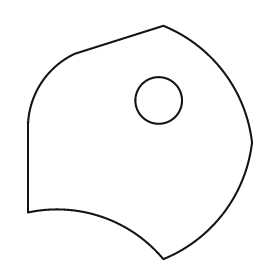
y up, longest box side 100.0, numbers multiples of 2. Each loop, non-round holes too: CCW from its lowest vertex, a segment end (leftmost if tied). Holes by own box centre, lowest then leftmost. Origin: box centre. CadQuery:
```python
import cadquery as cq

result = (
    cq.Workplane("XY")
    .moveTo(10.0, -50.0)
    .threePointArc((36.0, -30.0), (48.0, 0.0))
    .threePointArc((36.0, 30.0), (10.0, 50.0))
    .lineTo(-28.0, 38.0)
    .threePointArc((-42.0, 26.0), (-48.0, 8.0))
    .lineTo(-48.0, -30.0)
    .threePointArc((-16.0, -32.0), (10.0, -50.0))
    .close()
    .moveTo(8.0, 18.0)
    .circle(10.0)
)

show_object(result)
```